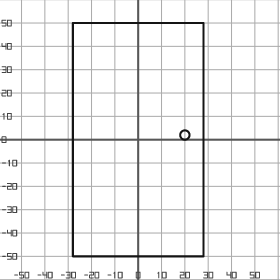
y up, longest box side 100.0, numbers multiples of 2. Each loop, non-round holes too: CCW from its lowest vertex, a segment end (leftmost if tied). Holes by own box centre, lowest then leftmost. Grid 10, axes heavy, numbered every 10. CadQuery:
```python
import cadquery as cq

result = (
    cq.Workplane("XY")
    .moveTo(-28.0, -50.0)
    .lineTo(28.0, -50.0)
    .lineTo(28.0, 50.0)
    .lineTo(-28.0, 50.0)
    .close()
    .moveTo(20.0, 2.0)
    .circle(2.0)
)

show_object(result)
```